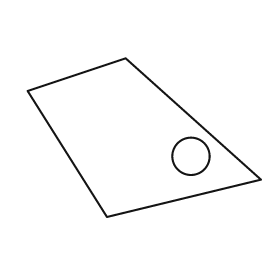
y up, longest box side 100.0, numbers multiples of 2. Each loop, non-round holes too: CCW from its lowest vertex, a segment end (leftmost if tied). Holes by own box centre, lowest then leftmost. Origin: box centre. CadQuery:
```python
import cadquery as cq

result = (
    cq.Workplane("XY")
    .moveTo(-16.0, -34.0)
    .lineTo(50.0, -18.0)
    .lineTo(-8.0, 34.0)
    .lineTo(-50.0, 20.0)
    .close()
    .moveTo(20.0, -8.0)
    .circle(8.0)
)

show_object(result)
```